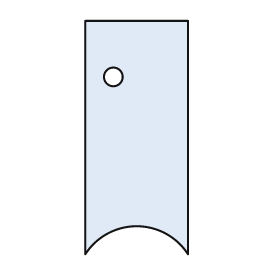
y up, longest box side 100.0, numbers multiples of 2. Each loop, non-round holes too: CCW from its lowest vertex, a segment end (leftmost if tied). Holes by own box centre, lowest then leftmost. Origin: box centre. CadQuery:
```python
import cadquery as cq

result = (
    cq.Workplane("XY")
    .moveTo(-22.0, -50.0)
    .threePointArc((0.0, -38.0), (22.0, -50.0))
    .lineTo(22.0, 50.0)
    .lineTo(-22.0, 50.0)
    .close()
    .moveTo(-10.0, 26.0)
    .circle(4.0)
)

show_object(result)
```